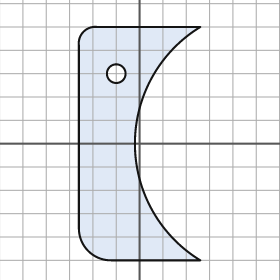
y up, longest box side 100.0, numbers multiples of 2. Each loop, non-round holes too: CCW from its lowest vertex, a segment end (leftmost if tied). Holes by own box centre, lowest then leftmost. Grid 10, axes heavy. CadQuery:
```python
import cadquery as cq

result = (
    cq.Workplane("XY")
    .moveTo(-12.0, -50.0)
    .lineTo(26.0, -50.0)
    .threePointArc((-2.0, 0.0), (26.0, 50.0))
    .lineTo(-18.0, 50.0)
    .threePointArc((-24.0, 48.0), (-26.0, 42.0))
    .lineTo(-26.0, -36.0)
    .threePointArc((-22.0, -46.0), (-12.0, -50.0))
    .close()
    .moveTo(-10.0, 30.0)
    .circle(4.0)
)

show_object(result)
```